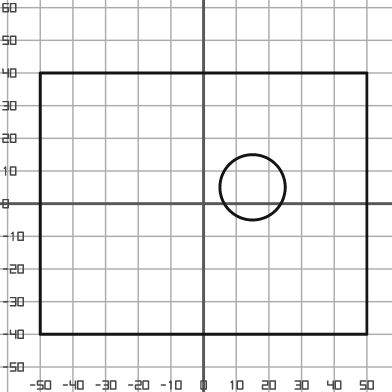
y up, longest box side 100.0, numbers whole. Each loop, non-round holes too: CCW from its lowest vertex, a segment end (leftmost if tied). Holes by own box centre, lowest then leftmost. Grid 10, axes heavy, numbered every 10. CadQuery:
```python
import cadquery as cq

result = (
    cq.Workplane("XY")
    .moveTo(-50.0, -40.0)
    .lineTo(50.0, -40.0)
    .lineTo(50.0, 40.0)
    .lineTo(-50.0, 40.0)
    .close()
    .moveTo(15.0, 5.0)
    .circle(10.0)
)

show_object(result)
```